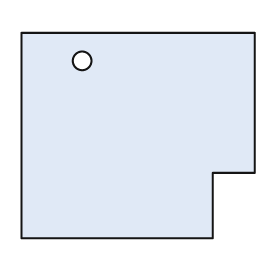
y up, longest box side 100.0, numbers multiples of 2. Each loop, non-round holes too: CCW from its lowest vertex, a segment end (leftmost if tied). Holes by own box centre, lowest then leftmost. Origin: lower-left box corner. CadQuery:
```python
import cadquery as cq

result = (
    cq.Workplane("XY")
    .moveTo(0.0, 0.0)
    .lineTo(82.0, 0.0)
    .lineTo(82.0, 28.0)
    .lineTo(100.0, 28.0)
    .lineTo(100.0, 88.0)
    .lineTo(0.0, 88.0)
    .close()
    .moveTo(26.0, 76.0)
    .circle(4.0)
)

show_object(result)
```